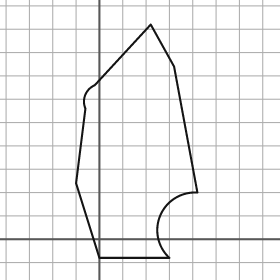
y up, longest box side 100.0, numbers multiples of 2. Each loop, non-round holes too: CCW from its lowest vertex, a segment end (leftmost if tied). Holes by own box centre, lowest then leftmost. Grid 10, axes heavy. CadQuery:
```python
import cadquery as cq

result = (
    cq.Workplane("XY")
    .moveTo(0.0, -8.0)
    .lineTo(30.0, -8.0)
    .threePointArc((26.0, 10.0), (42.0, 20.0))
    .lineTo(32.0, 74.0)
    .lineTo(22.0, 92.0)
    .lineTo(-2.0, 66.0)
    .threePointArc((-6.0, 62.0), (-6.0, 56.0))
    .lineTo(-10.0, 24.0)
    .close()
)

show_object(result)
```